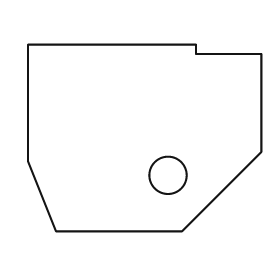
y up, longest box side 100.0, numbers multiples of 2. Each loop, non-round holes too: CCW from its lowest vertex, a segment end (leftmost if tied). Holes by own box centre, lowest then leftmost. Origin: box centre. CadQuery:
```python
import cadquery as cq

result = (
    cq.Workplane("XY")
    .moveTo(-38.0, -40.0)
    .lineTo(16.0, -40.0)
    .lineTo(50.0, -6.0)
    .lineTo(50.0, 36.0)
    .lineTo(22.0, 36.0)
    .lineTo(22.0, 40.0)
    .lineTo(-50.0, 40.0)
    .lineTo(-50.0, -10.0)
    .close()
    .moveTo(10.0, -16.0)
    .circle(8.0)
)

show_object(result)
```